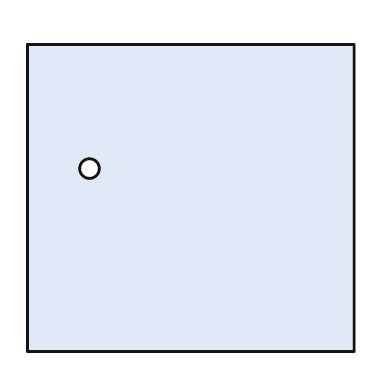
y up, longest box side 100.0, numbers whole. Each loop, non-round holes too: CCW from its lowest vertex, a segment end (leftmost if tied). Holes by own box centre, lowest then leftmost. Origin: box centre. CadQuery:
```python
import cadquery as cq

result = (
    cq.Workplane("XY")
    .moveTo(-50.0, -47.0)
    .lineTo(50.0, -47.0)
    .lineTo(50.0, 47.0)
    .lineTo(-50.0, 47.0)
    .close()
    .moveTo(-31.0, 9.0)
    .circle(3.0)
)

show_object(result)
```